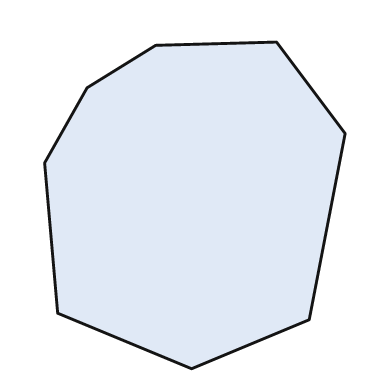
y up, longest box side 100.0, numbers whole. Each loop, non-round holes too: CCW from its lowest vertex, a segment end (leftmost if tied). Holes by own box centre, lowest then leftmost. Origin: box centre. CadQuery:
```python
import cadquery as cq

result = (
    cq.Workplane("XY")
    .moveTo(-1.0, -50.0)
    .lineTo(35.0, -35.0)
    .lineTo(46.0, 22.0)
    .lineTo(25.0, 50.0)
    .lineTo(-12.0, 49.0)
    .lineTo(-33.0, 36.0)
    .lineTo(-46.0, 13.0)
    .lineTo(-42.0, -33.0)
    .close()
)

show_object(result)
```